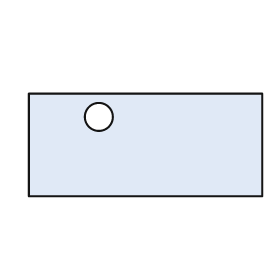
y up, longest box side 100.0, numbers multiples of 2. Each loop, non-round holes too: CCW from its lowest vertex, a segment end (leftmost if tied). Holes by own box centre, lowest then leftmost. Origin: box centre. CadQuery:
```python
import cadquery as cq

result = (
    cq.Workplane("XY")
    .moveTo(-50.0, -22.0)
    .lineTo(50.0, -22.0)
    .lineTo(50.0, 22.0)
    .lineTo(-50.0, 22.0)
    .close()
    .moveTo(-20.0, 12.0)
    .circle(6.0)
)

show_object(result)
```